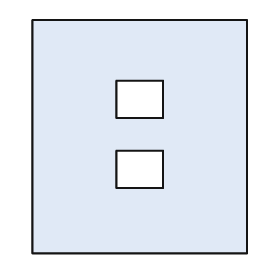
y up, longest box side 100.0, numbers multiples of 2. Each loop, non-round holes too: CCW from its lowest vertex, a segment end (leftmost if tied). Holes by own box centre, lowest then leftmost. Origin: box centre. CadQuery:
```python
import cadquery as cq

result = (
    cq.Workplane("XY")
    .moveTo(-46.0, -50.0)
    .lineTo(46.0, -50.0)
    .lineTo(46.0, 50.0)
    .lineTo(-46.0, 50.0)
    .close()
    .moveTo(-10.0, -22.0)
    .lineTo(10.0, -22.0)
    .lineTo(10.0, -6.0)
    .lineTo(-10.0, -6.0)
    .close()
    .moveTo(-10.0, 8.0)
    .lineTo(10.0, 8.0)
    .lineTo(10.0, 24.0)
    .lineTo(-10.0, 24.0)
    .close()
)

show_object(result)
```